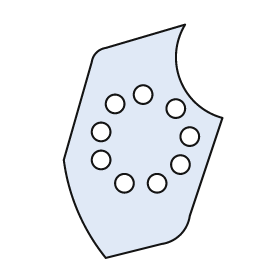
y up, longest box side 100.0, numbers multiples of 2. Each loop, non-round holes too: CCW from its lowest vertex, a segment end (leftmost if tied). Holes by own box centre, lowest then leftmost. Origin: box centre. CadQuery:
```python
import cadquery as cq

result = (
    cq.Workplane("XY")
    .moveTo(-16.0, -50.0)
    .lineTo(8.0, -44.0)
    .threePointArc((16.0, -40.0), (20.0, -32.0))
    .lineTo(34.0, 10.0)
    .threePointArc((16.0, 26.0), (18.0, 50.0))
    .lineTo(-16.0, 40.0)
    .threePointArc((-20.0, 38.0), (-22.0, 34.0))
    .lineTo(-34.0, -8.0)
    .threePointArc((-28.0, -30.0), (-16.0, -50.0))
    .close()
    .moveTo(-8.0, -18.0)
    .circle(4.0)
    .moveTo(6.0, -18.0)
    .circle(4.0)
    .moveTo(16.0, -10.0)
    .circle(4.0)
    .moveTo(-18.0, -8.0)
    .circle(4.0)
    .moveTo(20.0, 2.0)
    .circle(4.0)
    .moveTo(-18.0, 4.0)
    .circle(4.0)
    .moveTo(14.0, 14.0)
    .circle(4.0)
    .moveTo(-12.0, 16.0)
    .circle(4.0)
    .moveTo(0.0, 20.0)
    .circle(4.0)
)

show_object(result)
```